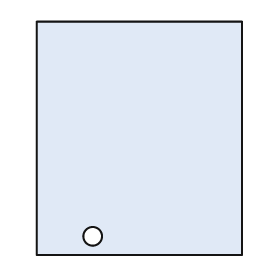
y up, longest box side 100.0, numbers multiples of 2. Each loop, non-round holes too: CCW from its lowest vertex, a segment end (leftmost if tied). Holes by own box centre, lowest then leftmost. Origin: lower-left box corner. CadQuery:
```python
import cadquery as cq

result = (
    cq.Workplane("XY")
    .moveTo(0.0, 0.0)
    .lineTo(88.0, 0.0)
    .lineTo(88.0, 100.0)
    .lineTo(0.0, 100.0)
    .close()
    .moveTo(24.0, 8.0)
    .circle(4.0)
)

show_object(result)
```